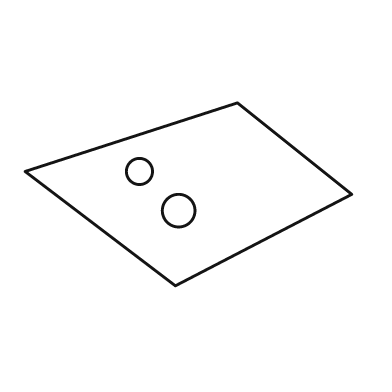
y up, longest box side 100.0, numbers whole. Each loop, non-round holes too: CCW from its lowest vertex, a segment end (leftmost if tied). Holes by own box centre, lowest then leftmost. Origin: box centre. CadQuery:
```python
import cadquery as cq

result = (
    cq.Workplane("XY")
    .moveTo(-4.0, -28.0)
    .lineTo(50.0, 0.0)
    .lineTo(15.0, 28.0)
    .lineTo(-50.0, 7.0)
    .close()
    .moveTo(-3.0, -5.0)
    .circle(5.0)
    .moveTo(-15.0, 7.0)
    .circle(4.0)
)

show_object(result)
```